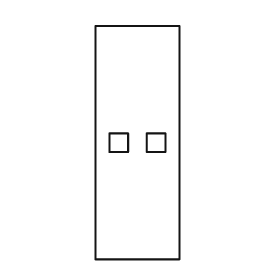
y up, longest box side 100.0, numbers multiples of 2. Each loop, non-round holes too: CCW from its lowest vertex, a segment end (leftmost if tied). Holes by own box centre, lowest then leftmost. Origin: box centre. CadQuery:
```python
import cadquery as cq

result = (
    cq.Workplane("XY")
    .moveTo(-18.0, -50.0)
    .lineTo(18.0, -50.0)
    .lineTo(18.0, 50.0)
    .lineTo(-18.0, 50.0)
    .close()
    .moveTo(-12.0, -4.0)
    .lineTo(-4.0, -4.0)
    .lineTo(-4.0, 4.0)
    .lineTo(-12.0, 4.0)
    .close()
    .moveTo(4.0, -4.0)
    .lineTo(12.0, -4.0)
    .lineTo(12.0, 4.0)
    .lineTo(4.0, 4.0)
    .close()
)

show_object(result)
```